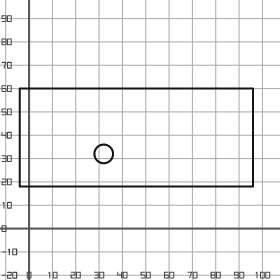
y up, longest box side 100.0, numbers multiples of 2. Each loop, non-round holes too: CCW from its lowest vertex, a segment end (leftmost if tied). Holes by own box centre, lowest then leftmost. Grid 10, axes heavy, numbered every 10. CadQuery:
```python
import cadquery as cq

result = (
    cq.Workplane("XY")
    .moveTo(-4.0, 18.0)
    .lineTo(96.0, 18.0)
    .lineTo(96.0, 60.0)
    .lineTo(-4.0, 60.0)
    .close()
    .moveTo(32.0, 32.0)
    .circle(4.0)
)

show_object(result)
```